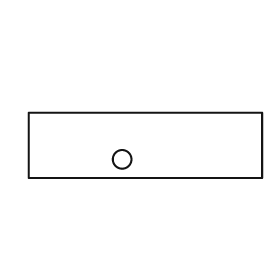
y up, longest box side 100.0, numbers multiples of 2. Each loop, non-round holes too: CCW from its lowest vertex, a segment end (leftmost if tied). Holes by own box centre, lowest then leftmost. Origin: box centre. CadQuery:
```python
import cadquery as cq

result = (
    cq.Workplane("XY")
    .moveTo(-50.0, -14.0)
    .lineTo(50.0, -14.0)
    .lineTo(50.0, 14.0)
    .lineTo(-50.0, 14.0)
    .close()
    .moveTo(-10.0, -6.0)
    .circle(4.0)
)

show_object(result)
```